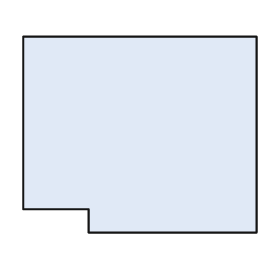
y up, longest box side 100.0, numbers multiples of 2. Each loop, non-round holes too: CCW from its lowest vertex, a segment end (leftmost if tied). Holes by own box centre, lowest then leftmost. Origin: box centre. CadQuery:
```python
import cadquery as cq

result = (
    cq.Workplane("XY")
    .moveTo(-22.0, -42.0)
    .lineTo(50.0, -42.0)
    .lineTo(50.0, 42.0)
    .lineTo(-50.0, 42.0)
    .lineTo(-50.0, -32.0)
    .lineTo(-22.0, -32.0)
    .close()
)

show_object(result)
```